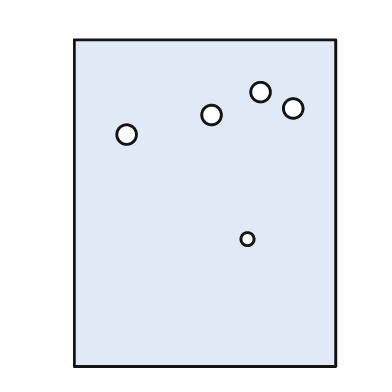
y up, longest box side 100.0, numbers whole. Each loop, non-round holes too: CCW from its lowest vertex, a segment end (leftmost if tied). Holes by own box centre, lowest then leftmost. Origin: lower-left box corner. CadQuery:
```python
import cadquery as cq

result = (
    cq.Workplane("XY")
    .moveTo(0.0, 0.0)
    .lineTo(80.0, 0.0)
    .lineTo(80.0, 100.0)
    .lineTo(0.0, 100.0)
    .close()
    .moveTo(53.0, 39.0)
    .circle(2.0)
    .moveTo(16.0, 71.0)
    .circle(3.0)
    .moveTo(42.0, 77.0)
    .circle(3.0)
    .moveTo(67.0, 79.0)
    .circle(3.0)
    .moveTo(57.0, 84.0)
    .circle(3.0)
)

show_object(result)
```